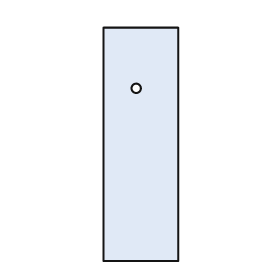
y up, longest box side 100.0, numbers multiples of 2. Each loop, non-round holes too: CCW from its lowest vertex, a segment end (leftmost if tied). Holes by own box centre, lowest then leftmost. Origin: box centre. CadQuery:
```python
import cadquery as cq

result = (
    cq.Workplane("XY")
    .moveTo(-16.0, -50.0)
    .lineTo(16.0, -50.0)
    .lineTo(16.0, 50.0)
    .lineTo(-16.0, 50.0)
    .close()
    .moveTo(-2.0, 24.0)
    .circle(2.0)
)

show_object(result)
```